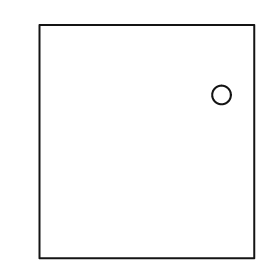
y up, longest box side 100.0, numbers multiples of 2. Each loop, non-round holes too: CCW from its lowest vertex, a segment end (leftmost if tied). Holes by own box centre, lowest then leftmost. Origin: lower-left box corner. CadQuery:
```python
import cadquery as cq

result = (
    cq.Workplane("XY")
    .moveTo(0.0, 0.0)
    .lineTo(92.0, 0.0)
    .lineTo(92.0, 100.0)
    .lineTo(0.0, 100.0)
    .close()
    .moveTo(78.0, 70.0)
    .circle(4.0)
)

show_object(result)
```